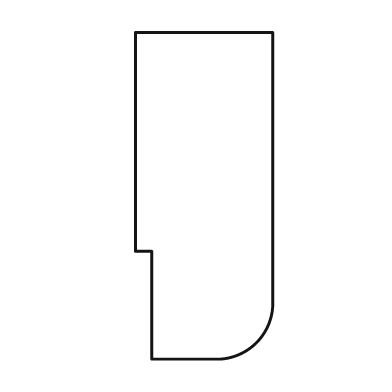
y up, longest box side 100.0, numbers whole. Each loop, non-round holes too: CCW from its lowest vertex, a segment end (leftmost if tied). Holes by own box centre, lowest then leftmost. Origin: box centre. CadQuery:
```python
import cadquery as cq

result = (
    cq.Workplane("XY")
    .moveTo(-16.0, -50.0)
    .lineTo(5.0, -50.0)
    .threePointArc((16.0, -45.0), (21.0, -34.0))
    .lineTo(21.0, 50.0)
    .lineTo(-21.0, 50.0)
    .lineTo(-21.0, -17.0)
    .lineTo(-16.0, -17.0)
    .close()
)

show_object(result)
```